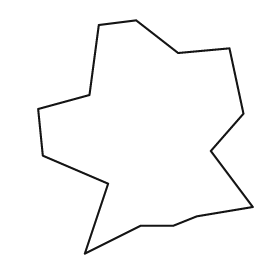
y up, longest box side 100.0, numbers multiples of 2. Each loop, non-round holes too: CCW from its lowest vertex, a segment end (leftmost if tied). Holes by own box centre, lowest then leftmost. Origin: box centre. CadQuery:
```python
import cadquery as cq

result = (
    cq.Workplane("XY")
    .moveTo(-26.0, -50.0)
    .lineTo(-2.0, -38.0)
    .lineTo(12.0, -38.0)
    .lineTo(22.0, -34.0)
    .lineTo(46.0, -30.0)
    .lineTo(28.0, -6.0)
    .lineTo(42.0, 10.0)
    .lineTo(36.0, 38.0)
    .lineTo(14.0, 36.0)
    .lineTo(-4.0, 50.0)
    .lineTo(-20.0, 48.0)
    .lineTo(-24.0, 18.0)
    .lineTo(-46.0, 12.0)
    .lineTo(-44.0, -8.0)
    .lineTo(-16.0, -20.0)
    .close()
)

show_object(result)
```